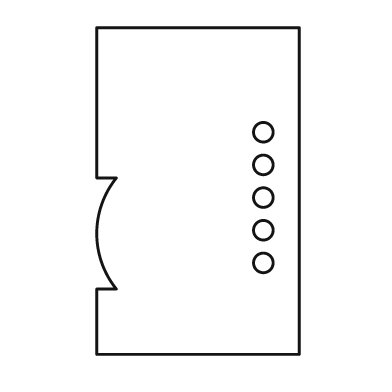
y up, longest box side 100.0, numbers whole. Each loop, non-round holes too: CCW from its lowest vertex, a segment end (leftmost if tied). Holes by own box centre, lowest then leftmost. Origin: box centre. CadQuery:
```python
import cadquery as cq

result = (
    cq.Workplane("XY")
    .moveTo(-31.0, -50.0)
    .lineTo(31.0, -50.0)
    .lineTo(31.0, 50.0)
    .lineTo(-31.0, 50.0)
    .lineTo(-31.0, 4.0)
    .lineTo(-25.0, 4.0)
    .threePointArc((-31.0, -13.0), (-25.0, -30.0))
    .lineTo(-31.0, -30.0)
    .close()
    .moveTo(20.0, -22.0)
    .circle(3.0)
    .moveTo(20.0, -12.0)
    .circle(3.0)
    .moveTo(20.0, -2.0)
    .circle(3.0)
    .moveTo(20.0, 8.0)
    .circle(3.0)
    .moveTo(20.0, 18.0)
    .circle(3.0)
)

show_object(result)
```